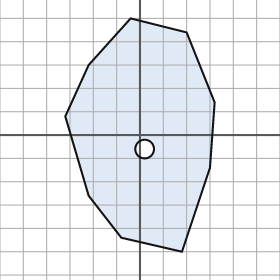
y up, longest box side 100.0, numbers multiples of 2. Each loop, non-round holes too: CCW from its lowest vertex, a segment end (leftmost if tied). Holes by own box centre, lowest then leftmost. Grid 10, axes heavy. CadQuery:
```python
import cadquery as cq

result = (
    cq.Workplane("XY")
    .moveTo(18.0, -50.0)
    .lineTo(30.0, -14.0)
    .lineTo(32.0, 14.0)
    .lineTo(20.0, 44.0)
    .lineTo(-4.0, 50.0)
    .lineTo(-22.0, 30.0)
    .lineTo(-32.0, 8.0)
    .lineTo(-22.0, -26.0)
    .lineTo(-8.0, -44.0)
    .close()
    .moveTo(2.0, -6.0)
    .circle(4.0)
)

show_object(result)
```